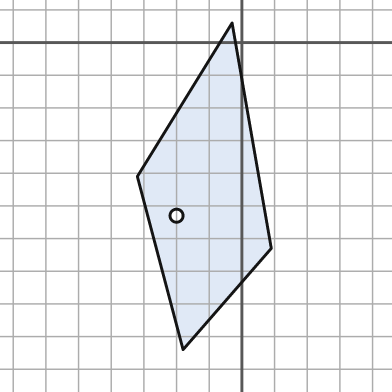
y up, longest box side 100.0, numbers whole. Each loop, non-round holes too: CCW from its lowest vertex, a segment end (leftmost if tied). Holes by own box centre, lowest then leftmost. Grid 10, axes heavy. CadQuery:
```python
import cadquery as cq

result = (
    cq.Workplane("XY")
    .moveTo(-18.0, -94.0)
    .lineTo(9.0, -63.0)
    .lineTo(-3.0, 6.0)
    .lineTo(-32.0, -41.0)
    .close()
    .moveTo(-20.0, -53.0)
    .circle(2.0)
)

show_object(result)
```